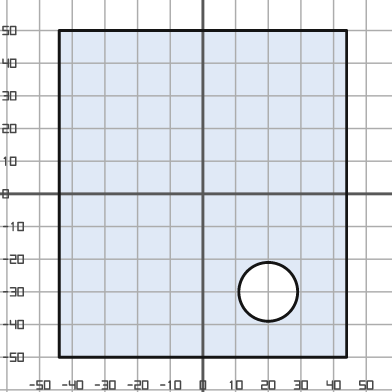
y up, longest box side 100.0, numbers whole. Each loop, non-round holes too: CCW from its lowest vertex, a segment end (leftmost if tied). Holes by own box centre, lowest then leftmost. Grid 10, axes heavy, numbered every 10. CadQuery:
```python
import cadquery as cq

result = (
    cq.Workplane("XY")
    .moveTo(-44.0, -50.0)
    .lineTo(44.0, -50.0)
    .lineTo(44.0, 50.0)
    .lineTo(-44.0, 50.0)
    .close()
    .moveTo(20.0, -30.0)
    .circle(9.0)
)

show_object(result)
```